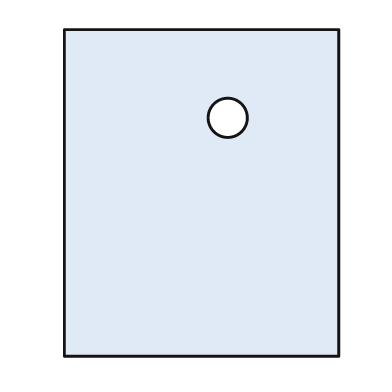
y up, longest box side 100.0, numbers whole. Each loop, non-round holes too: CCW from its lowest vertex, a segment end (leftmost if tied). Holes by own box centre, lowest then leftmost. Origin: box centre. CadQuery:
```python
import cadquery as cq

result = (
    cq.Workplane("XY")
    .moveTo(-42.0, -50.0)
    .lineTo(42.0, -50.0)
    .lineTo(42.0, 50.0)
    .lineTo(-42.0, 50.0)
    .close()
    .moveTo(8.0, 23.0)
    .circle(6.0)
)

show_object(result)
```